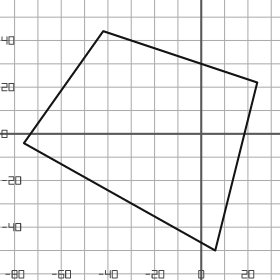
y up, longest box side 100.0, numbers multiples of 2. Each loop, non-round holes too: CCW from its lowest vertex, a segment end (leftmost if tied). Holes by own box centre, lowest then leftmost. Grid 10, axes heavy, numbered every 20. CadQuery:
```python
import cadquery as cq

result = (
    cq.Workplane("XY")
    .moveTo(6.0, -50.0)
    .lineTo(24.0, 22.0)
    .lineTo(-42.0, 44.0)
    .lineTo(-76.0, -4.0)
    .close()
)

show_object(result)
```